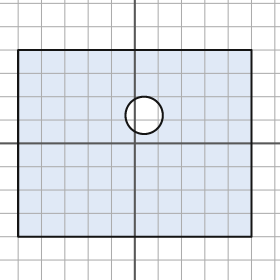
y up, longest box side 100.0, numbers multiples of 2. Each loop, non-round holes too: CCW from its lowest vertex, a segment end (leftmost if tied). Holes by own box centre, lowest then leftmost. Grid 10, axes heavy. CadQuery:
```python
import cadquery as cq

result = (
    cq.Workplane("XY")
    .moveTo(-50.0, -40.0)
    .lineTo(50.0, -40.0)
    .lineTo(50.0, 40.0)
    .lineTo(-50.0, 40.0)
    .close()
    .moveTo(4.0, 12.0)
    .circle(8.0)
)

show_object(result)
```